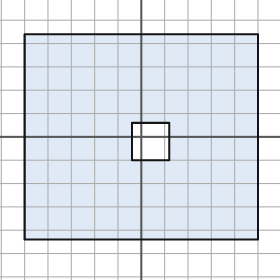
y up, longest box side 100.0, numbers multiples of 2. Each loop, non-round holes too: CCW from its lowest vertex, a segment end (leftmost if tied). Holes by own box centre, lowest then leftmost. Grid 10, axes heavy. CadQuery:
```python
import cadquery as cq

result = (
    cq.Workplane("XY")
    .moveTo(-50.0, -44.0)
    .lineTo(50.0, -44.0)
    .lineTo(50.0, 44.0)
    .lineTo(-50.0, 44.0)
    .close()
    .moveTo(-4.0, -10.0)
    .lineTo(12.0, -10.0)
    .lineTo(12.0, 6.0)
    .lineTo(-4.0, 6.0)
    .close()
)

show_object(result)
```